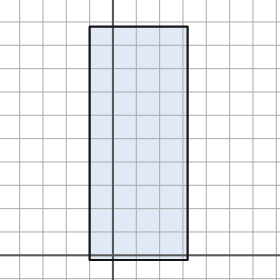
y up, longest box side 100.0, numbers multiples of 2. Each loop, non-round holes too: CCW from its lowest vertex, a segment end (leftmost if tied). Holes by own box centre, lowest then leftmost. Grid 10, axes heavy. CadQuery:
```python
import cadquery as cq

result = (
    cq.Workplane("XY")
    .moveTo(-10.0, -2.0)
    .lineTo(32.0, -2.0)
    .lineTo(32.0, 98.0)
    .lineTo(-10.0, 98.0)
    .close()
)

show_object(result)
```